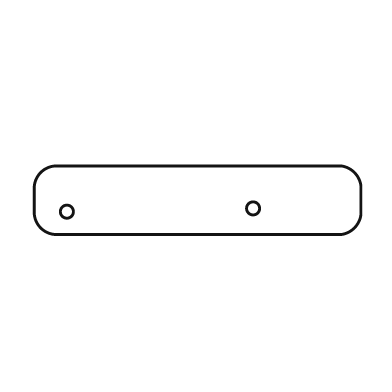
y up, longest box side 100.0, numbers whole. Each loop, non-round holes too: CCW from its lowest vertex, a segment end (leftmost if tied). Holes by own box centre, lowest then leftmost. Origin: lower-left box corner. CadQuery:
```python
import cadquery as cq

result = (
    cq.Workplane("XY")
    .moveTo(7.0, 0.0)
    .lineTo(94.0, 0.0)
    .threePointArc((98.0, 2.0), (100.0, 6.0))
    .lineTo(100.0, 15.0)
    .threePointArc((98.0, 19.0), (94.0, 21.0))
    .lineTo(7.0, 21.0)
    .threePointArc((2.0, 19.0), (0.0, 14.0))
    .lineTo(0.0, 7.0)
    .threePointArc((2.0, 2.0), (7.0, 0.0))
    .close()
    .moveTo(10.0, 7.0)
    .circle(2.0)
    .moveTo(67.0, 8.0)
    .circle(2.0)
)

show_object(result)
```